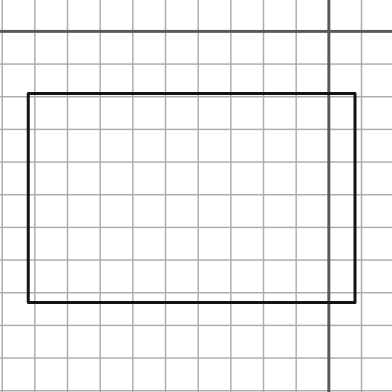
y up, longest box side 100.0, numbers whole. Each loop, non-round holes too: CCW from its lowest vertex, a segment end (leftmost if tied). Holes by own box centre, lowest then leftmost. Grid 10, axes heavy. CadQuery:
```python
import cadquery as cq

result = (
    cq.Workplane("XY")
    .moveTo(-92.0, -83.0)
    .lineTo(8.0, -83.0)
    .lineTo(8.0, -19.0)
    .lineTo(-92.0, -19.0)
    .close()
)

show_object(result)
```